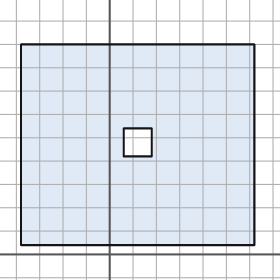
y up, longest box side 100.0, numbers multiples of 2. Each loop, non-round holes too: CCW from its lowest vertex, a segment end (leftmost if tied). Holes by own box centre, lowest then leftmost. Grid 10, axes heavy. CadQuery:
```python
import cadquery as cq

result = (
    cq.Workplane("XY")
    .moveTo(-38.0, 4.0)
    .lineTo(62.0, 4.0)
    .lineTo(62.0, 90.0)
    .lineTo(-38.0, 90.0)
    .close()
    .moveTo(6.0, 42.0)
    .lineTo(18.0, 42.0)
    .lineTo(18.0, 54.0)
    .lineTo(6.0, 54.0)
    .close()
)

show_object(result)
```